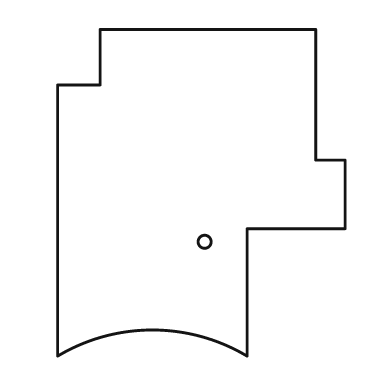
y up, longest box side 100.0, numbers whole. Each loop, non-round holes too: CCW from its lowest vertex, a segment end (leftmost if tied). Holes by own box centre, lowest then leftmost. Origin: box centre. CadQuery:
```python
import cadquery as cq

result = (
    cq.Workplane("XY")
    .moveTo(-44.0, -50.0)
    .threePointArc((-15.0, -42.0), (14.0, -50.0))
    .lineTo(14.0, -11.0)
    .lineTo(44.0, -11.0)
    .lineTo(44.0, 10.0)
    .lineTo(35.0, 10.0)
    .lineTo(35.0, 50.0)
    .lineTo(-31.0, 50.0)
    .lineTo(-31.0, 33.0)
    .lineTo(-44.0, 33.0)
    .close()
    .moveTo(1.0, -15.0)
    .circle(2.0)
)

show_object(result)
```